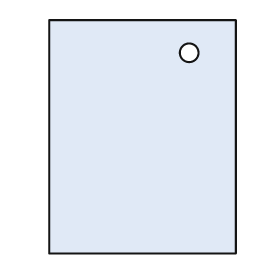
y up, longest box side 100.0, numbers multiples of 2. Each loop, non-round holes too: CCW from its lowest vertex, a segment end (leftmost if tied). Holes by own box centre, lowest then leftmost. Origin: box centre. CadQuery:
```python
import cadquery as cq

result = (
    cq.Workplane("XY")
    .moveTo(-40.0, -50.0)
    .lineTo(40.0, -50.0)
    .lineTo(40.0, 50.0)
    .lineTo(-40.0, 50.0)
    .close()
    .moveTo(20.0, 36.0)
    .circle(4.0)
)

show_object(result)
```